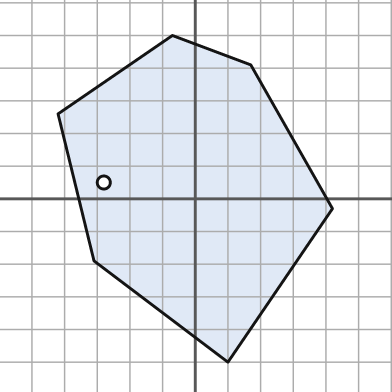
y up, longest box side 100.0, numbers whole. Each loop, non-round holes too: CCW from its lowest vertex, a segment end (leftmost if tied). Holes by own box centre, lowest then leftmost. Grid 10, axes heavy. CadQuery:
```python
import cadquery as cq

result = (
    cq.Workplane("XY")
    .moveTo(10.0, -50.0)
    .lineTo(42.0, -3.0)
    .lineTo(17.0, 41.0)
    .lineTo(-7.0, 50.0)
    .lineTo(-42.0, 26.0)
    .lineTo(-31.0, -19.0)
    .close()
    .moveTo(-28.0, 5.0)
    .circle(2.0)
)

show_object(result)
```